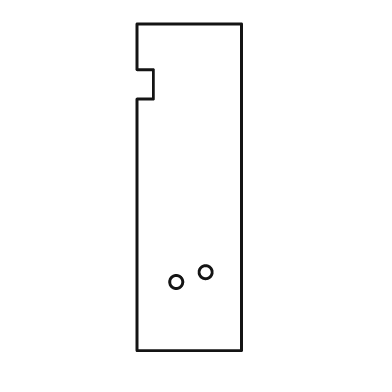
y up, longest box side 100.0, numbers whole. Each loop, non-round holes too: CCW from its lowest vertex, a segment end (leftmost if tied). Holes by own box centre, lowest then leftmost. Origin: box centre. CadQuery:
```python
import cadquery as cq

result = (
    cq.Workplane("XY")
    .moveTo(-16.0, -50.0)
    .lineTo(16.0, -50.0)
    .lineTo(16.0, 50.0)
    .lineTo(-16.0, 50.0)
    .lineTo(-16.0, 36.0)
    .lineTo(-11.0, 36.0)
    .lineTo(-11.0, 27.0)
    .lineTo(-16.0, 27.0)
    .close()
    .moveTo(-4.0, -29.0)
    .circle(2.0)
    .moveTo(5.0, -26.0)
    .circle(2.0)
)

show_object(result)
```